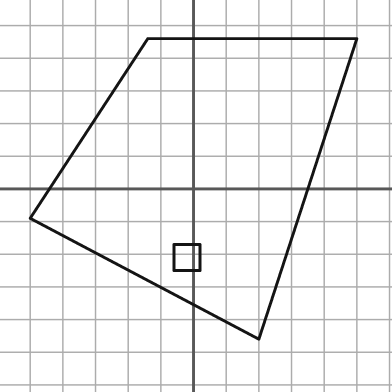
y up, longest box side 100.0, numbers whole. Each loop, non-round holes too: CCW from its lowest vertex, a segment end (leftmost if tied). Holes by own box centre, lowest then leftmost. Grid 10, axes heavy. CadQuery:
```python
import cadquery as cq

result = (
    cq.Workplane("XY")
    .moveTo(20.0, -46.0)
    .lineTo(50.0, 46.0)
    .lineTo(-14.0, 46.0)
    .lineTo(-50.0, -9.0)
    .close()
    .moveTo(-6.0, -25.0)
    .lineTo(2.0, -25.0)
    .lineTo(2.0, -17.0)
    .lineTo(-6.0, -17.0)
    .close()
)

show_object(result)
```